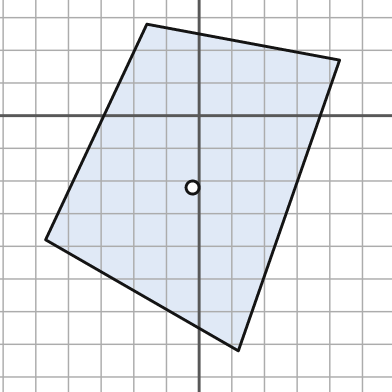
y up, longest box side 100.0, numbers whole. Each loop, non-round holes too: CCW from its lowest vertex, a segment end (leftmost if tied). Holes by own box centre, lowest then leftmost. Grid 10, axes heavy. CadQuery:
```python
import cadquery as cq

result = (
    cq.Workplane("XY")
    .moveTo(12.0, -72.0)
    .lineTo(43.0, 17.0)
    .lineTo(-16.0, 28.0)
    .lineTo(-47.0, -38.0)
    .close()
    .moveTo(-2.0, -22.0)
    .circle(2.0)
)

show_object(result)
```